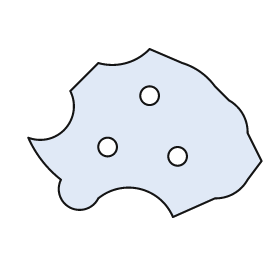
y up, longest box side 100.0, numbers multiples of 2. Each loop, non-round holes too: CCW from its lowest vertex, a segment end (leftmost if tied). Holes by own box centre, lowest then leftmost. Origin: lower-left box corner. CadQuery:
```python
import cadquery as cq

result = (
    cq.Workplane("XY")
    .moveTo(62.0, 0.0)
    .lineTo(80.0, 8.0)
    .threePointArc((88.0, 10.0), (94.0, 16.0))
    .lineTo(100.0, 24.0)
    .lineTo(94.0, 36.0)
    .threePointArc((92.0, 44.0), (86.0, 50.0))
    .lineTo(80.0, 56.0)
    .threePointArc((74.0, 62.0), (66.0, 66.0))
    .lineTo(52.0, 72.0)
    .threePointArc((42.0, 66.0), (30.0, 66.0))
    .lineTo(18.0, 54.0)
    .threePointArc((16.0, 38.0), (0.0, 34.0))
    .threePointArc((6.0, 24.0), (14.0, 16.0))
    .threePointArc((18.0, 4.0), (30.0, 8.0))
    .threePointArc((48.0, 12.0), (62.0, 0.0))
    .close()
    .moveTo(64.0, 26.0)
    .circle(4.0)
    .moveTo(34.0, 30.0)
    .circle(4.0)
    .moveTo(52.0, 52.0)
    .circle(4.0)
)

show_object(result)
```